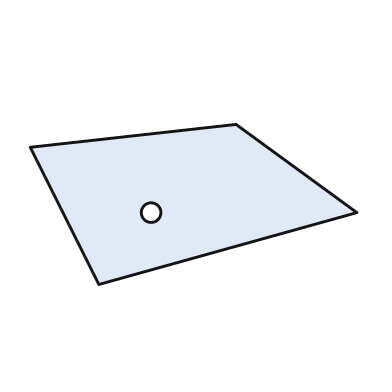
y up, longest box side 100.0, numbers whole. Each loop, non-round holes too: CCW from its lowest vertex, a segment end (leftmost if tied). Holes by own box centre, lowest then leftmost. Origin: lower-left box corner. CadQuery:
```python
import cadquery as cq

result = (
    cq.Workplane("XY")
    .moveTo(21.0, 0.0)
    .lineTo(100.0, 22.0)
    .lineTo(63.0, 49.0)
    .lineTo(0.0, 42.0)
    .close()
    .moveTo(37.0, 22.0)
    .circle(3.0)
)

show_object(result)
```